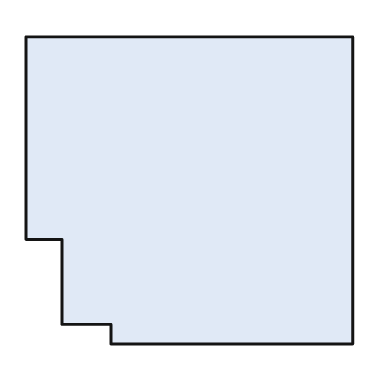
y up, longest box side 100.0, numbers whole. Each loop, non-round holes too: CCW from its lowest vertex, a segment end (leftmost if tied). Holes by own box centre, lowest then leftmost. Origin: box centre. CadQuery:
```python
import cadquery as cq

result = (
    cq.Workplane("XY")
    .moveTo(-24.0, -47.0)
    .lineTo(50.0, -47.0)
    .lineTo(50.0, 47.0)
    .lineTo(-50.0, 47.0)
    .lineTo(-50.0, -15.0)
    .lineTo(-39.0, -15.0)
    .lineTo(-39.0, -41.0)
    .lineTo(-24.0, -41.0)
    .close()
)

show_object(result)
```